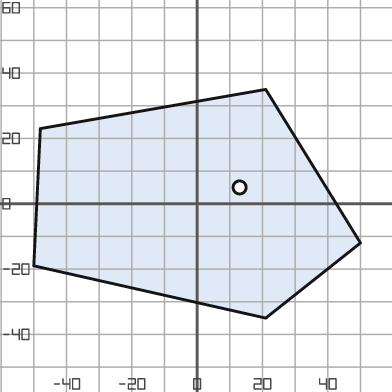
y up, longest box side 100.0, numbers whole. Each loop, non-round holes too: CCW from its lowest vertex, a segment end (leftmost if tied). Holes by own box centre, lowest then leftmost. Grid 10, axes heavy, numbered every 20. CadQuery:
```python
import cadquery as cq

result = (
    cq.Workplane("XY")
    .moveTo(21.0, -35.0)
    .lineTo(50.0, -12.0)
    .lineTo(21.0, 35.0)
    .lineTo(-48.0, 23.0)
    .lineTo(-50.0, -19.0)
    .close()
    .moveTo(13.0, 5.0)
    .circle(2.0)
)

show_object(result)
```